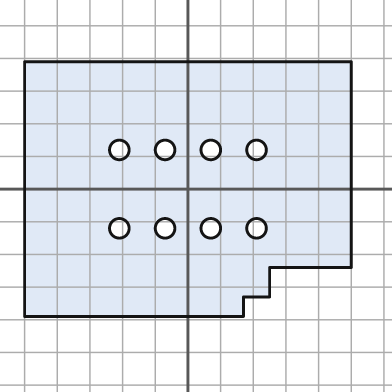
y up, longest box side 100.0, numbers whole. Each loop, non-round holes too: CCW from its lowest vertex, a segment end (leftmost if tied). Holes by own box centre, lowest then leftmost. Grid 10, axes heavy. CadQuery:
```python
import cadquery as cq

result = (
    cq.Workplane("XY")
    .moveTo(-50.0, -39.0)
    .lineTo(17.0, -39.0)
    .lineTo(17.0, -33.0)
    .lineTo(25.0, -33.0)
    .lineTo(25.0, -24.0)
    .lineTo(50.0, -24.0)
    .lineTo(50.0, 39.0)
    .lineTo(-50.0, 39.0)
    .close()
    .moveTo(-21.0, -12.0)
    .circle(3.0)
    .moveTo(-7.0, -12.0)
    .circle(3.0)
    .moveTo(7.0, -12.0)
    .circle(3.0)
    .moveTo(21.0, -12.0)
    .circle(3.0)
    .moveTo(-21.0, 12.0)
    .circle(3.0)
    .moveTo(-7.0, 12.0)
    .circle(3.0)
    .moveTo(7.0, 12.0)
    .circle(3.0)
    .moveTo(21.0, 12.0)
    .circle(3.0)
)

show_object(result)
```